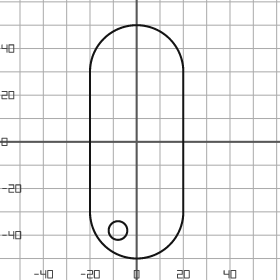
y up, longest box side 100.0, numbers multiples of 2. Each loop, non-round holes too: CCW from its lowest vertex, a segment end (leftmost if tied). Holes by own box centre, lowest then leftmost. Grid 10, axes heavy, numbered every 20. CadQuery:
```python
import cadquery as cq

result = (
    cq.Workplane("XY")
    .moveTo(-20.0, -30.0)
    .threePointArc((0.0, -50.0), (20.0, -30.0))
    .lineTo(20.0, 30.0)
    .threePointArc((0.0, 50.0), (-20.0, 30.0))
    .close()
    .moveTo(-8.0, -38.0)
    .circle(4.0)
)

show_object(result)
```